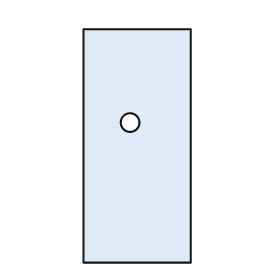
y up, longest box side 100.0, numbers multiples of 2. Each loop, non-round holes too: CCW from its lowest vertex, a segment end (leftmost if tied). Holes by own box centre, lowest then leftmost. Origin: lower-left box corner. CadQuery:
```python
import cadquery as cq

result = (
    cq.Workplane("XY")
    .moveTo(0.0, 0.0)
    .lineTo(46.0, 0.0)
    .lineTo(46.0, 100.0)
    .lineTo(0.0, 100.0)
    .close()
    .moveTo(20.0, 60.0)
    .circle(4.0)
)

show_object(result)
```